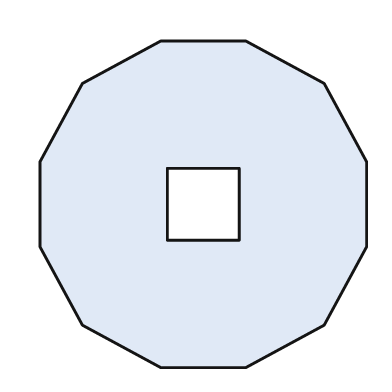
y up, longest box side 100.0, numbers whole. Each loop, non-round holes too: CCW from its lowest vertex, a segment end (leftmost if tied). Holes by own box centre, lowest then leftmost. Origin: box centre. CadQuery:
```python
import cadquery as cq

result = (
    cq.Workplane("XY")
    .moveTo(-13.0, -50.0)
    .lineTo(13.0, -50.0)
    .lineTo(37.0, -37.0)
    .lineTo(50.0, -13.0)
    .lineTo(50.0, 13.0)
    .lineTo(37.0, 37.0)
    .lineTo(13.0, 50.0)
    .lineTo(-13.0, 50.0)
    .lineTo(-37.0, 37.0)
    .lineTo(-50.0, 13.0)
    .lineTo(-50.0, -13.0)
    .lineTo(-37.0, -37.0)
    .close()
    .moveTo(-11.0, -11.0)
    .lineTo(11.0, -11.0)
    .lineTo(11.0, 11.0)
    .lineTo(-11.0, 11.0)
    .close()
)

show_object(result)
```